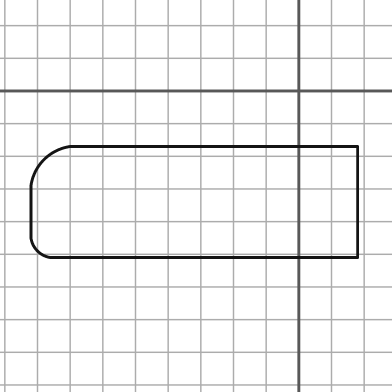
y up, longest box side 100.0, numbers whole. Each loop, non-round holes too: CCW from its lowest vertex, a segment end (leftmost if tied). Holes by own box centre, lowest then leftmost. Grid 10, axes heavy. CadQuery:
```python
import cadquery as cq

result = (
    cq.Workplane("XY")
    .moveTo(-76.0, -51.0)
    .lineTo(18.0, -51.0)
    .lineTo(18.0, -17.0)
    .lineTo(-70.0, -17.0)
    .threePointArc((-78.0, -21.0), (-82.0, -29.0))
    .lineTo(-82.0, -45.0)
    .threePointArc((-80.0, -49.0), (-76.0, -51.0))
    .close()
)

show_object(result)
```